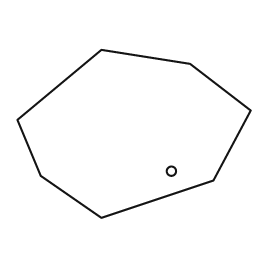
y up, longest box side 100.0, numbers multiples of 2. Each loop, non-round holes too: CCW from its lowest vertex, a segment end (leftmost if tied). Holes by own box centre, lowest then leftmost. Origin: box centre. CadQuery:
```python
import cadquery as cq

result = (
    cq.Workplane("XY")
    .moveTo(-14.0, -36.0)
    .lineTo(34.0, -20.0)
    .lineTo(50.0, 10.0)
    .lineTo(24.0, 30.0)
    .lineTo(-14.0, 36.0)
    .lineTo(-50.0, 6.0)
    .lineTo(-40.0, -18.0)
    .close()
    .moveTo(16.0, -16.0)
    .circle(2.0)
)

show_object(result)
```